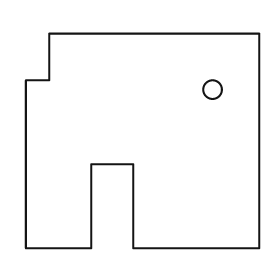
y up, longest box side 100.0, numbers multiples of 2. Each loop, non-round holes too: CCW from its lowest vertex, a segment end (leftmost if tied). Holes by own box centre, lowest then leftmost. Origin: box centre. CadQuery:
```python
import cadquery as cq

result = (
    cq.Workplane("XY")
    .moveTo(-50.0, -46.0)
    .lineTo(-22.0, -46.0)
    .lineTo(-22.0, -10.0)
    .lineTo(-4.0, -10.0)
    .lineTo(-4.0, -46.0)
    .lineTo(50.0, -46.0)
    .lineTo(50.0, 46.0)
    .lineTo(-40.0, 46.0)
    .lineTo(-40.0, 26.0)
    .lineTo(-50.0, 26.0)
    .close()
    .moveTo(30.0, 22.0)
    .circle(4.0)
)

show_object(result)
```